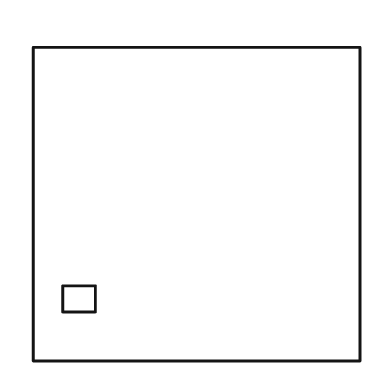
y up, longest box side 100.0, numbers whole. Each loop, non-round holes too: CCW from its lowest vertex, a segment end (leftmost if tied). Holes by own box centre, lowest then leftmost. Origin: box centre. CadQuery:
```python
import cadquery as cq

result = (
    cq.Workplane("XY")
    .moveTo(-50.0, -48.0)
    .lineTo(50.0, -48.0)
    .lineTo(50.0, 48.0)
    .lineTo(-50.0, 48.0)
    .close()
    .moveTo(-41.0, -33.0)
    .lineTo(-31.0, -33.0)
    .lineTo(-31.0, -25.0)
    .lineTo(-41.0, -25.0)
    .close()
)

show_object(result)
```